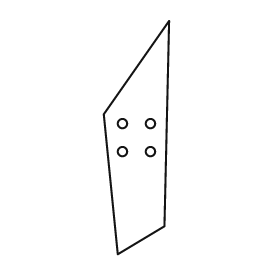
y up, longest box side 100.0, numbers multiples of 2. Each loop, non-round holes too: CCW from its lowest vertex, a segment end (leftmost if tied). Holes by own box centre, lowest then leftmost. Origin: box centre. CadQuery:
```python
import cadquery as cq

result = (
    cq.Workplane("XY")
    .moveTo(-8.0, -50.0)
    .lineTo(12.0, -38.0)
    .lineTo(14.0, 50.0)
    .lineTo(-14.0, 10.0)
    .close()
    .moveTo(-6.0, -6.0)
    .circle(2.0)
    .moveTo(6.0, -6.0)
    .circle(2.0)
    .moveTo(-6.0, 6.0)
    .circle(2.0)
    .moveTo(6.0, 6.0)
    .circle(2.0)
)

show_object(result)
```